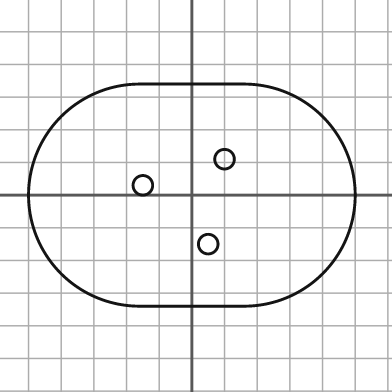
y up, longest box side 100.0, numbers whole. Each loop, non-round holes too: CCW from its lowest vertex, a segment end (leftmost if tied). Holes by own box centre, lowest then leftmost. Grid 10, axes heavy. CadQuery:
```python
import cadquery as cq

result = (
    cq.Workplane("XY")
    .moveTo(-16.0, -34.0)
    .lineTo(16.0, -34.0)
    .threePointArc((50.0, 0.0), (16.0, 34.0))
    .lineTo(-16.0, 34.0)
    .threePointArc((-50.0, 0.0), (-16.0, -34.0))
    .close()
    .moveTo(5.0, -15.0)
    .circle(3.0)
    .moveTo(-15.0, 3.0)
    .circle(3.0)
    .moveTo(10.0, 11.0)
    .circle(3.0)
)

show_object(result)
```